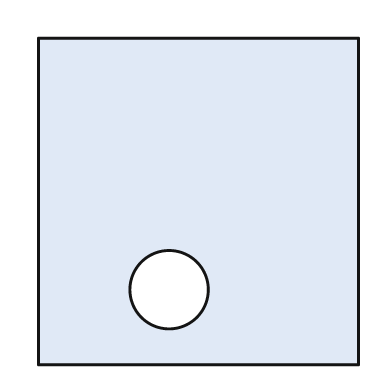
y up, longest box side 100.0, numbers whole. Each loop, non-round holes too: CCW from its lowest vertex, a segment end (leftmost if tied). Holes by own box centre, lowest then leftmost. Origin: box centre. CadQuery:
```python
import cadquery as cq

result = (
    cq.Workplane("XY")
    .moveTo(-49.0, -50.0)
    .lineTo(49.0, -50.0)
    .lineTo(49.0, 50.0)
    .lineTo(-49.0, 50.0)
    .close()
    .moveTo(-9.0, -27.0)
    .circle(12.0)
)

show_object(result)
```